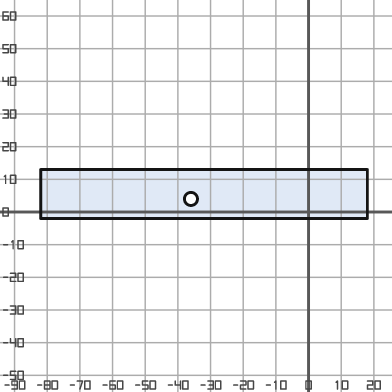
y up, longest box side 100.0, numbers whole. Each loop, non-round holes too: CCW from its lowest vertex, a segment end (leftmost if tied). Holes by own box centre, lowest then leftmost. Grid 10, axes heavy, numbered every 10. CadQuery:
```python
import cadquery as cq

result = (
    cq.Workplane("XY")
    .moveTo(-82.0, -2.0)
    .lineTo(18.0, -2.0)
    .lineTo(18.0, 13.0)
    .lineTo(-82.0, 13.0)
    .close()
    .moveTo(-36.0, 4.0)
    .circle(2.0)
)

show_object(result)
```